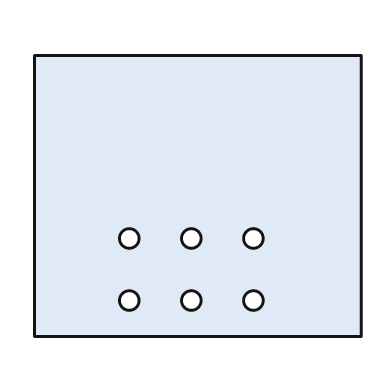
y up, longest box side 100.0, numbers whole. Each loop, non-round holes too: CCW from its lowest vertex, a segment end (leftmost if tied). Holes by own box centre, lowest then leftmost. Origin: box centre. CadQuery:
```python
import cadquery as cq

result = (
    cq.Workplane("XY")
    .moveTo(-50.0, -43.0)
    .lineTo(50.0, -43.0)
    .lineTo(50.0, 43.0)
    .lineTo(-50.0, 43.0)
    .close()
    .moveTo(-21.0, -32.0)
    .circle(3.0)
    .moveTo(-2.0, -32.0)
    .circle(3.0)
    .moveTo(17.0, -32.0)
    .circle(3.0)
    .moveTo(-21.0, -13.0)
    .circle(3.0)
    .moveTo(-2.0, -13.0)
    .circle(3.0)
    .moveTo(17.0, -13.0)
    .circle(3.0)
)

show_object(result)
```